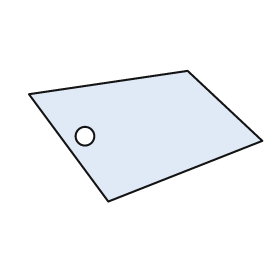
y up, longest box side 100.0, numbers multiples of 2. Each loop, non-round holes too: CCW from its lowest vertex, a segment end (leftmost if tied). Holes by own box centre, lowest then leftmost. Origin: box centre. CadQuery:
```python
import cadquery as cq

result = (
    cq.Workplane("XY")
    .moveTo(-16.0, -28.0)
    .lineTo(50.0, -2.0)
    .lineTo(18.0, 28.0)
    .lineTo(-50.0, 18.0)
    .close()
    .moveTo(-26.0, 0.0)
    .circle(4.0)
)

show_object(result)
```